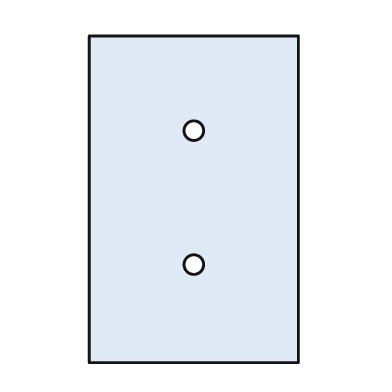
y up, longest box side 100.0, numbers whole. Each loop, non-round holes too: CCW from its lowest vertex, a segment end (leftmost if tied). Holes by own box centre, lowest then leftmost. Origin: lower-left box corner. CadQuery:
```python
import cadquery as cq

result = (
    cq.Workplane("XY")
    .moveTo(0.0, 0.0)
    .lineTo(64.0, 0.0)
    .lineTo(64.0, 100.0)
    .lineTo(0.0, 100.0)
    .close()
    .moveTo(32.0, 30.0)
    .circle(3.0)
    .moveTo(32.0, 71.0)
    .circle(3.0)
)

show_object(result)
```